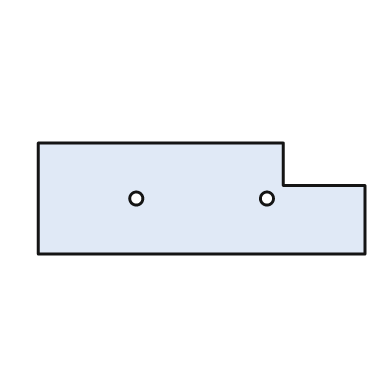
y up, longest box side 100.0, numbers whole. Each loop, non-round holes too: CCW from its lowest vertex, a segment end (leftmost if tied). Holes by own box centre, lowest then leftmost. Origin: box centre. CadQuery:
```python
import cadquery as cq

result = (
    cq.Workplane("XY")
    .moveTo(-50.0, -17.0)
    .lineTo(50.0, -17.0)
    .lineTo(50.0, 4.0)
    .lineTo(25.0, 4.0)
    .lineTo(25.0, 17.0)
    .lineTo(-50.0, 17.0)
    .close()
    .moveTo(-20.0, 0.0)
    .circle(2.0)
    .moveTo(20.0, 0.0)
    .circle(2.0)
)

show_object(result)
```